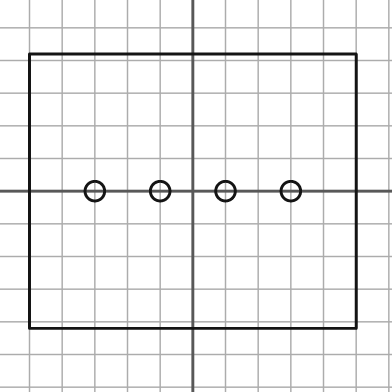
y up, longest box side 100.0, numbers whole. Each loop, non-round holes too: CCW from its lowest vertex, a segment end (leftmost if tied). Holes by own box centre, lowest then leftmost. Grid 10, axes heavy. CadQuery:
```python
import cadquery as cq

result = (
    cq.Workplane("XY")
    .moveTo(-50.0, -42.0)
    .lineTo(50.0, -42.0)
    .lineTo(50.0, 42.0)
    .lineTo(-50.0, 42.0)
    .close()
    .moveTo(-30.0, 0.0)
    .circle(3.0)
    .moveTo(-10.0, 0.0)
    .circle(3.0)
    .moveTo(10.0, 0.0)
    .circle(3.0)
    .moveTo(30.0, 0.0)
    .circle(3.0)
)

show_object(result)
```